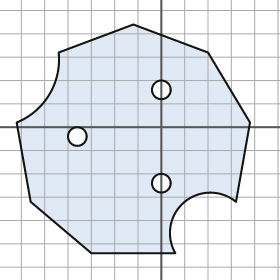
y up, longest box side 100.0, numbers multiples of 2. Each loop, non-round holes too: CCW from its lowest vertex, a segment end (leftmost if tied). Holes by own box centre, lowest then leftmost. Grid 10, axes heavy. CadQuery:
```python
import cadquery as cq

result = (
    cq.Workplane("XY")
    .moveTo(-30.0, -54.0)
    .lineTo(6.0, -54.0)
    .threePointArc((10.0, -32.0), (32.0, -32.0))
    .lineTo(38.0, 2.0)
    .lineTo(20.0, 32.0)
    .lineTo(-12.0, 44.0)
    .lineTo(-44.0, 32.0)
    .threePointArc((-48.0, 14.0), (-62.0, 2.0))
    .lineTo(-56.0, -32.0)
    .close()
    .moveTo(0.0, -24.0)
    .circle(4.0)
    .moveTo(-36.0, -4.0)
    .circle(4.0)
    .moveTo(0.0, 16.0)
    .circle(4.0)
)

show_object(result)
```